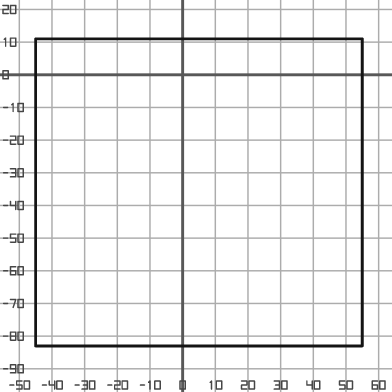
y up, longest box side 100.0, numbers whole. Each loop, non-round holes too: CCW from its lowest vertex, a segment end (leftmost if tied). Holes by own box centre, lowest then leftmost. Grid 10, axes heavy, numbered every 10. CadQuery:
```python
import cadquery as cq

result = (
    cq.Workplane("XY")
    .moveTo(-45.0, -83.0)
    .lineTo(55.0, -83.0)
    .lineTo(55.0, 11.0)
    .lineTo(-45.0, 11.0)
    .close()
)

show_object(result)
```